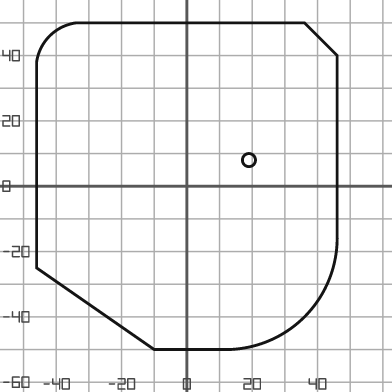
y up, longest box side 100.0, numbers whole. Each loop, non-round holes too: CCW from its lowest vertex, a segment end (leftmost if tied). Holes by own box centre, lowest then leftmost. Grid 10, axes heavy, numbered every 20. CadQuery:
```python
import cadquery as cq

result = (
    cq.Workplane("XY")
    .moveTo(-10.0, -50.0)
    .lineTo(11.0, -50.0)
    .threePointArc((36.0, -40.0), (46.0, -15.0))
    .lineTo(46.0, 40.0)
    .lineTo(36.0, 50.0)
    .lineTo(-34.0, 50.0)
    .threePointArc((-42.0, 46.0), (-46.0, 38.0))
    .lineTo(-46.0, -25.0)
    .close()
    .moveTo(19.0, 8.0)
    .circle(2.0)
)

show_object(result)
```